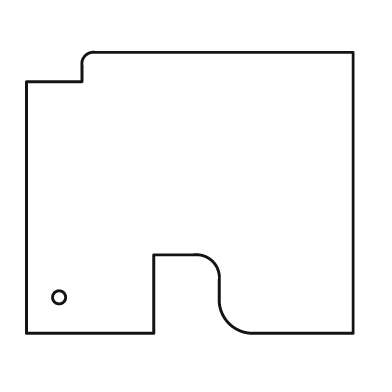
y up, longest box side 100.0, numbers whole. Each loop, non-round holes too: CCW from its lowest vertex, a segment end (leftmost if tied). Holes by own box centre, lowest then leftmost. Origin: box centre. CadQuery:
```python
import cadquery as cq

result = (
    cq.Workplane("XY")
    .moveTo(-50.0, -43.0)
    .lineTo(-11.0, -43.0)
    .lineTo(-11.0, -19.0)
    .lineTo(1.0, -19.0)
    .threePointArc((7.0, -21.0), (9.0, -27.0))
    .lineTo(9.0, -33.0)
    .threePointArc((12.0, -40.0), (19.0, -43.0))
    .lineTo(50.0, -43.0)
    .lineTo(50.0, 43.0)
    .lineTo(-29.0, 43.0)
    .threePointArc((-32.0, 42.0), (-33.0, 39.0))
    .lineTo(-33.0, 34.0)
    .lineTo(-50.0, 34.0)
    .close()
    .moveTo(-40.0, -32.0)
    .circle(2.0)
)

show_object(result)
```